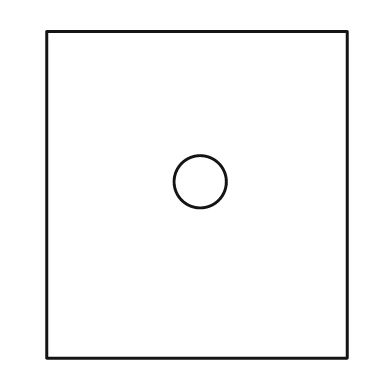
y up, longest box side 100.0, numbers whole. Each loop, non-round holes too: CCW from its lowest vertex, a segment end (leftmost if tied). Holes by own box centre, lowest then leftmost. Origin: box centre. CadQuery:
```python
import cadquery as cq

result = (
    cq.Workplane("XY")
    .moveTo(-46.0, -50.0)
    .lineTo(46.0, -50.0)
    .lineTo(46.0, 50.0)
    .lineTo(-46.0, 50.0)
    .close()
    .moveTo(1.0, 4.0)
    .circle(8.0)
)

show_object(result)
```